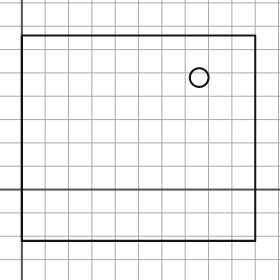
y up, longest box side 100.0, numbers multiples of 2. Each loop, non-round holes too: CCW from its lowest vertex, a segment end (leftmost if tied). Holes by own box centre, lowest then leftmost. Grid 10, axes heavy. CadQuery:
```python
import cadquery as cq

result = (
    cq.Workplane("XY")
    .moveTo(0.0, -22.0)
    .lineTo(100.0, -22.0)
    .lineTo(100.0, 66.0)
    .lineTo(0.0, 66.0)
    .close()
    .moveTo(76.0, 48.0)
    .circle(4.0)
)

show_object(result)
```